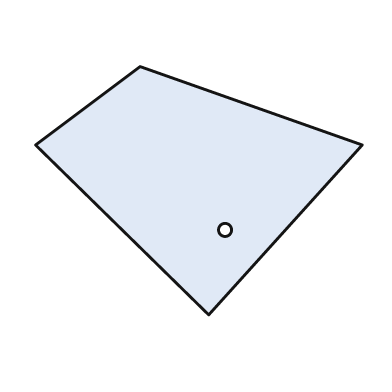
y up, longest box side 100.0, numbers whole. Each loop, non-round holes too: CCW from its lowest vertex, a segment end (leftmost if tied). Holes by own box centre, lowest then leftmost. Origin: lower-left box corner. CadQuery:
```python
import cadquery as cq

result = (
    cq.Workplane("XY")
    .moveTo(53.0, 0.0)
    .lineTo(100.0, 52.0)
    .lineTo(32.0, 76.0)
    .lineTo(0.0, 52.0)
    .close()
    .moveTo(58.0, 26.0)
    .circle(2.0)
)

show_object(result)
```